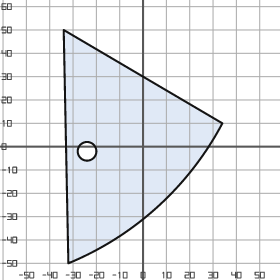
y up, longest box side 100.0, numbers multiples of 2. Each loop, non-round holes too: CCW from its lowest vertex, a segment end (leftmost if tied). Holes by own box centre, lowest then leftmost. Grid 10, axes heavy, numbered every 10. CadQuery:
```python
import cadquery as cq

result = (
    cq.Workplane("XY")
    .moveTo(-32.0, -50.0)
    .threePointArc((6.0, -26.0), (34.0, 10.0))
    .lineTo(-34.0, 50.0)
    .close()
    .moveTo(-24.0, -2.0)
    .circle(4.0)
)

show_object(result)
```